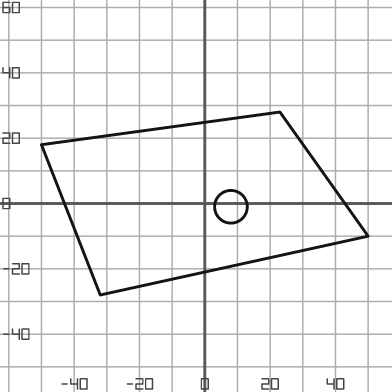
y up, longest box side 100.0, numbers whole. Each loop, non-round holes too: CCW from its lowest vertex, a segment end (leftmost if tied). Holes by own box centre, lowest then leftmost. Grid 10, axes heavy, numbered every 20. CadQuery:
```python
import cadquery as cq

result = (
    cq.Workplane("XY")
    .moveTo(-32.0, -28.0)
    .lineTo(50.0, -10.0)
    .lineTo(23.0, 28.0)
    .lineTo(-50.0, 18.0)
    .close()
    .moveTo(8.0, -1.0)
    .circle(5.0)
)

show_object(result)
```